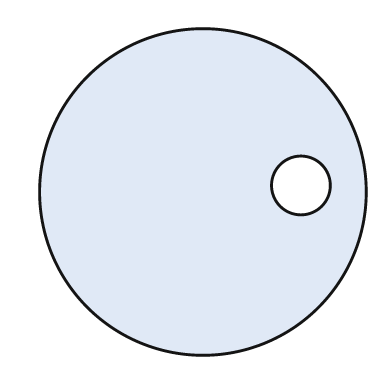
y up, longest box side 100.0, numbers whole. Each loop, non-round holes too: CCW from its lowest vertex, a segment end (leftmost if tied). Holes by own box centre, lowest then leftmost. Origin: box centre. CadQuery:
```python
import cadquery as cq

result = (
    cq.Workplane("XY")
    .moveTo(0.0, 0.0)
    .circle(50.0)
    .moveTo(30.0, 2.0)
    .circle(9.0)
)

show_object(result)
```